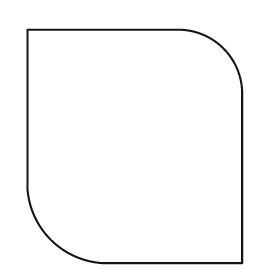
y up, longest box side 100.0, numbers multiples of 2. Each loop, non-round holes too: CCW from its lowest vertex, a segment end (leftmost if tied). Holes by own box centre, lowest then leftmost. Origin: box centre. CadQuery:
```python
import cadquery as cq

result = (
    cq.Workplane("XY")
    .moveTo(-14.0, -50.0)
    .lineTo(46.0, -50.0)
    .lineTo(46.0, 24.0)
    .threePointArc((38.0, 42.0), (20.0, 50.0))
    .lineTo(-46.0, 50.0)
    .lineTo(-46.0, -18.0)
    .threePointArc((-36.0, -40.0), (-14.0, -50.0))
    .close()
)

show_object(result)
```